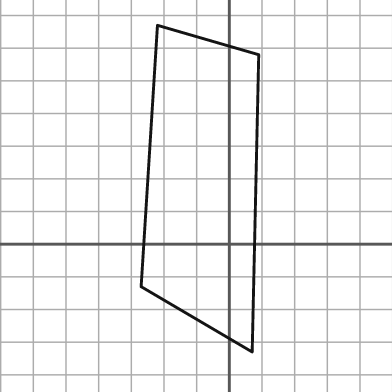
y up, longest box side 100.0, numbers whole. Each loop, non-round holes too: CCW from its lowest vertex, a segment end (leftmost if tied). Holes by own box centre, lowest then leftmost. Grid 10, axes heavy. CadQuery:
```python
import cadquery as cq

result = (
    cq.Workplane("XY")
    .moveTo(7.0, -33.0)
    .lineTo(9.0, 58.0)
    .lineTo(-22.0, 67.0)
    .lineTo(-27.0, -13.0)
    .close()
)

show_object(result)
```